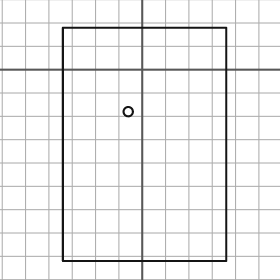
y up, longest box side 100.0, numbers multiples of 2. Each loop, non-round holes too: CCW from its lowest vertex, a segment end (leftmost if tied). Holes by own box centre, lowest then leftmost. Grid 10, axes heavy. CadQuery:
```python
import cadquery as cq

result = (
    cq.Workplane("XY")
    .moveTo(-34.0, -82.0)
    .lineTo(36.0, -82.0)
    .lineTo(36.0, 18.0)
    .lineTo(-34.0, 18.0)
    .close()
    .moveTo(-6.0, -18.0)
    .circle(2.0)
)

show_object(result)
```